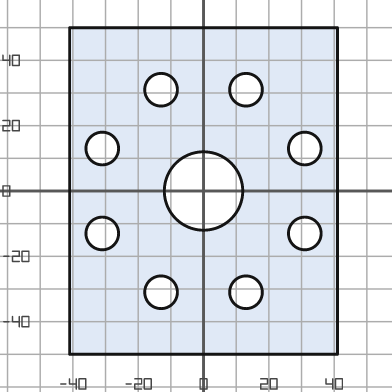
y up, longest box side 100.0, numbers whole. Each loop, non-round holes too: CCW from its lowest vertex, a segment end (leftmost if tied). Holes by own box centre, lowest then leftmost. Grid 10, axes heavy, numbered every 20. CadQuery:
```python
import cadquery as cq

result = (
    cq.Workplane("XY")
    .moveTo(-41.0, -50.0)
    .lineTo(41.0, -50.0)
    .lineTo(41.0, 50.0)
    .lineTo(-41.0, 50.0)
    .close()
    .moveTo(-13.0, -31.0)
    .circle(5.0)
    .moveTo(13.0, -31.0)
    .circle(5.0)
    .moveTo(-31.0, -13.0)
    .circle(5.0)
    .moveTo(31.0, -13.0)
    .circle(5.0)
    .moveTo(0.0, 0.0)
    .circle(12.0)
    .moveTo(-31.0, 13.0)
    .circle(5.0)
    .moveTo(31.0, 13.0)
    .circle(5.0)
    .moveTo(-13.0, 31.0)
    .circle(5.0)
    .moveTo(13.0, 31.0)
    .circle(5.0)
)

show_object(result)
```